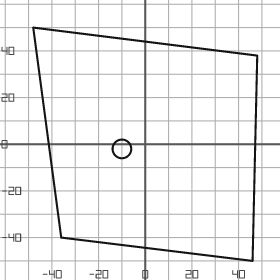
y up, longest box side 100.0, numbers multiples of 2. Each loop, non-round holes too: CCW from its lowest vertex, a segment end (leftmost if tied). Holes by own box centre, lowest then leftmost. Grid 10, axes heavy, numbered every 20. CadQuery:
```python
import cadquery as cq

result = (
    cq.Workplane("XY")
    .moveTo(46.0, -50.0)
    .lineTo(48.0, 38.0)
    .lineTo(-48.0, 50.0)
    .lineTo(-36.0, -40.0)
    .close()
    .moveTo(-10.0, -2.0)
    .circle(4.0)
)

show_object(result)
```